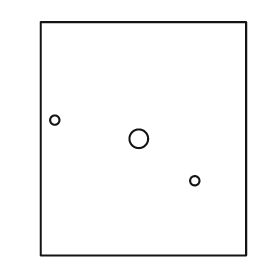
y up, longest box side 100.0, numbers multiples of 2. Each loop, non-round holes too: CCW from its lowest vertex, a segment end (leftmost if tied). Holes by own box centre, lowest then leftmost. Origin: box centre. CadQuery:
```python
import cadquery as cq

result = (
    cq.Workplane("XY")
    .moveTo(-44.0, -50.0)
    .lineTo(44.0, -50.0)
    .lineTo(44.0, 50.0)
    .lineTo(-44.0, 50.0)
    .close()
    .moveTo(22.0, -18.0)
    .circle(2.0)
    .moveTo(-2.0, 0.0)
    .circle(4.0)
    .moveTo(-38.0, 8.0)
    .circle(2.0)
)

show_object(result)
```